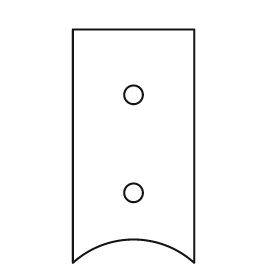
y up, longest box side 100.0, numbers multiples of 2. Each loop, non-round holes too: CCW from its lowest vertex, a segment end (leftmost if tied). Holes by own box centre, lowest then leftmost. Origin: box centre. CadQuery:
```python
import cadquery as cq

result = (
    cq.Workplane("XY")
    .moveTo(-26.0, -50.0)
    .threePointArc((0.0, -40.0), (26.0, -50.0))
    .lineTo(26.0, 50.0)
    .lineTo(-26.0, 50.0)
    .close()
    .moveTo(0.0, -20.0)
    .circle(4.0)
    .moveTo(0.0, 22.0)
    .circle(4.0)
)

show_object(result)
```